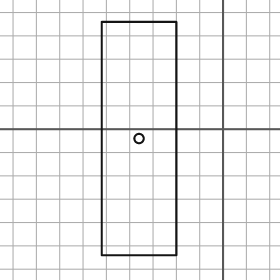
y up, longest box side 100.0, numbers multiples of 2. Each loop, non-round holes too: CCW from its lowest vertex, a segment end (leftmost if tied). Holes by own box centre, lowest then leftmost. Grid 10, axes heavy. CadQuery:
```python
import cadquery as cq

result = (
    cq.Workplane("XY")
    .moveTo(-52.0, -54.0)
    .lineTo(-20.0, -54.0)
    .lineTo(-20.0, 46.0)
    .lineTo(-52.0, 46.0)
    .close()
    .moveTo(-36.0, -4.0)
    .circle(2.0)
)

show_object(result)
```